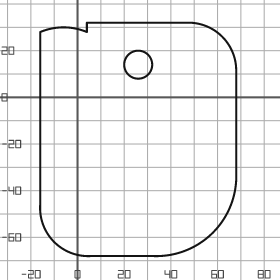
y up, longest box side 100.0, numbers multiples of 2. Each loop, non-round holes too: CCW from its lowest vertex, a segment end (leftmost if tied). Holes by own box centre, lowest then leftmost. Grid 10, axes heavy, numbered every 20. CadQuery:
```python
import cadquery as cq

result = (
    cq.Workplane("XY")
    .moveTo(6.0, -68.0)
    .lineTo(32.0, -68.0)
    .threePointArc((58.0, -58.0), (68.0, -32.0))
    .lineTo(68.0, 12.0)
    .threePointArc((62.0, 26.0), (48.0, 32.0))
    .lineTo(4.0, 32.0)
    .lineTo(4.0, 28.0)
    .threePointArc((-6.0, 30.0), (-16.0, 28.0))
    .lineTo(-16.0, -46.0)
    .threePointArc((-10.0, -62.0), (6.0, -68.0))
    .close()
    .moveTo(26.0, 14.0)
    .circle(6.0)
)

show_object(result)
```